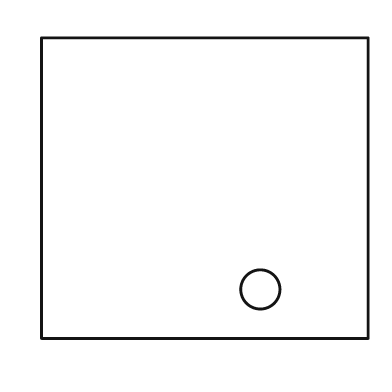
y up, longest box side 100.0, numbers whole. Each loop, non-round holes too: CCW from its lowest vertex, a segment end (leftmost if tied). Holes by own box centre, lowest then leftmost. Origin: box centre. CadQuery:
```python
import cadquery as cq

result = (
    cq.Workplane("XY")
    .moveTo(-50.0, -46.0)
    .lineTo(50.0, -46.0)
    .lineTo(50.0, 46.0)
    .lineTo(-50.0, 46.0)
    .close()
    .moveTo(17.0, -31.0)
    .circle(6.0)
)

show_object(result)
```